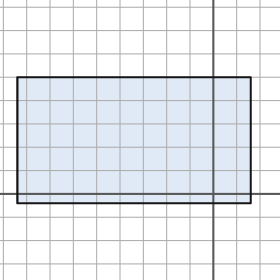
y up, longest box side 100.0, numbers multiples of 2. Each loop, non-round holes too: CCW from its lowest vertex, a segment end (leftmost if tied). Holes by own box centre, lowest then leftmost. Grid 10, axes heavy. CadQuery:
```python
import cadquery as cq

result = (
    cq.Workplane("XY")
    .moveTo(-84.0, -4.0)
    .lineTo(16.0, -4.0)
    .lineTo(16.0, 50.0)
    .lineTo(-84.0, 50.0)
    .close()
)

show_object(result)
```